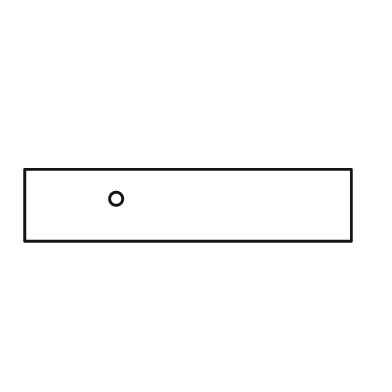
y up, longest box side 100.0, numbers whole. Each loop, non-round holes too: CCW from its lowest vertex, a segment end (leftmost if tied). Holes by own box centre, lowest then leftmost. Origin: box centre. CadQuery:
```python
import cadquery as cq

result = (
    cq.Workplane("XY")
    .moveTo(-50.0, -11.0)
    .lineTo(50.0, -11.0)
    .lineTo(50.0, 11.0)
    .lineTo(-50.0, 11.0)
    .close()
    .moveTo(-22.0, 2.0)
    .circle(2.0)
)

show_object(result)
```